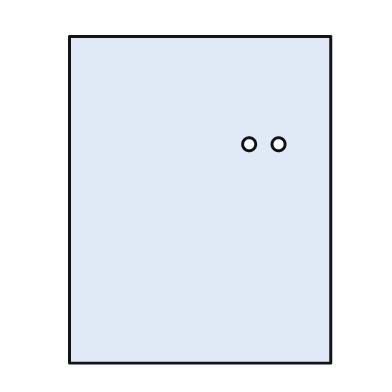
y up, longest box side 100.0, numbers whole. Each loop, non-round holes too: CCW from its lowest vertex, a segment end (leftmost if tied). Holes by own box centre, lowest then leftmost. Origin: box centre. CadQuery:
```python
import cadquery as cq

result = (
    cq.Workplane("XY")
    .moveTo(-40.0, -50.0)
    .lineTo(40.0, -50.0)
    .lineTo(40.0, 50.0)
    .lineTo(-40.0, 50.0)
    .close()
    .moveTo(15.0, 17.0)
    .circle(2.0)
    .moveTo(24.0, 17.0)
    .circle(2.0)
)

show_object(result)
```